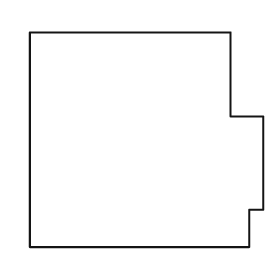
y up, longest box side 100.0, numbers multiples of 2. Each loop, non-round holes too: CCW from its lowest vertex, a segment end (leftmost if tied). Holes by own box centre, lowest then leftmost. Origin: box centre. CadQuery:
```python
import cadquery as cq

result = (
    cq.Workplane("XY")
    .moveTo(-50.0, -46.0)
    .lineTo(44.0, -46.0)
    .lineTo(44.0, -30.0)
    .lineTo(50.0, -30.0)
    .lineTo(50.0, 10.0)
    .lineTo(36.0, 10.0)
    .lineTo(36.0, 46.0)
    .lineTo(-50.0, 46.0)
    .close()
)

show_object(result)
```